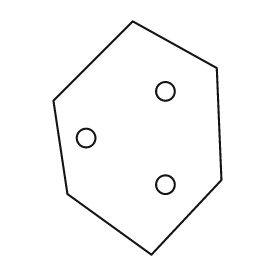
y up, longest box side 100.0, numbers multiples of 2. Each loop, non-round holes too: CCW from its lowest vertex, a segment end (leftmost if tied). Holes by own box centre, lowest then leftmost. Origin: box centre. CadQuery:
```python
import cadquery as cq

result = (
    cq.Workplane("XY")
    .moveTo(6.0, -50.0)
    .lineTo(36.0, -18.0)
    .lineTo(34.0, 30.0)
    .lineTo(-2.0, 50.0)
    .lineTo(-36.0, 16.0)
    .lineTo(-30.0, -24.0)
    .close()
    .moveTo(12.0, -20.0)
    .circle(4.0)
    .moveTo(-22.0, 0.0)
    .circle(4.0)
    .moveTo(12.0, 20.0)
    .circle(4.0)
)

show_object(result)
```